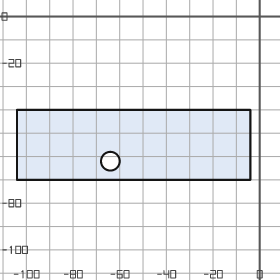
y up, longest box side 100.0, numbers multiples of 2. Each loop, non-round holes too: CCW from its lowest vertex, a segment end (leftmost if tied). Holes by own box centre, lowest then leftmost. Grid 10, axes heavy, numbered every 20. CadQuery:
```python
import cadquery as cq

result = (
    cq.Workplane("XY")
    .moveTo(-104.0, -70.0)
    .lineTo(-4.0, -70.0)
    .lineTo(-4.0, -40.0)
    .lineTo(-104.0, -40.0)
    .close()
    .moveTo(-64.0, -62.0)
    .circle(4.0)
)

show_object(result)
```